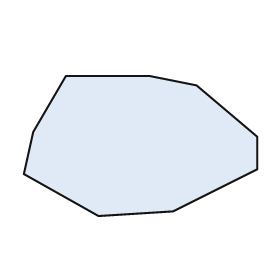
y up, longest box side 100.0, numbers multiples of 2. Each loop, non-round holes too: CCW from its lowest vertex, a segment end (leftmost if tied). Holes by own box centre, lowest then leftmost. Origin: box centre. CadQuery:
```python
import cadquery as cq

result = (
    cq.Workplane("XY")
    .moveTo(-18.0, -30.0)
    .lineTo(14.0, -28.0)
    .lineTo(50.0, -10.0)
    .lineTo(50.0, 4.0)
    .lineTo(24.0, 26.0)
    .lineTo(4.0, 30.0)
    .lineTo(-32.0, 30.0)
    .lineTo(-46.0, 6.0)
    .lineTo(-50.0, -12.0)
    .close()
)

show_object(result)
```